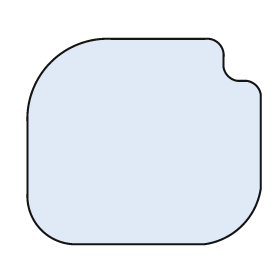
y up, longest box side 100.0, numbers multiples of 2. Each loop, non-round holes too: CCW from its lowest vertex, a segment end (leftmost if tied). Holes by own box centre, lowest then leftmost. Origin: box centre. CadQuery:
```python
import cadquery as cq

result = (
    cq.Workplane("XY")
    .moveTo(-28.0, -44.0)
    .lineTo(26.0, -44.0)
    .threePointArc((42.0, -36.0), (50.0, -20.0))
    .lineTo(50.0, 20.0)
    .threePointArc((48.0, 24.0), (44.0, 26.0))
    .lineTo(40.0, 26.0)
    .threePointArc((36.0, 28.0), (34.0, 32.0))
    .lineTo(34.0, 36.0)
    .threePointArc((32.0, 42.0), (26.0, 44.0))
    .lineTo(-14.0, 44.0)
    .threePointArc((-40.0, 34.0), (-50.0, 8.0))
    .lineTo(-50.0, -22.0)
    .threePointArc((-44.0, -38.0), (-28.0, -44.0))
    .close()
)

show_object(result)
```